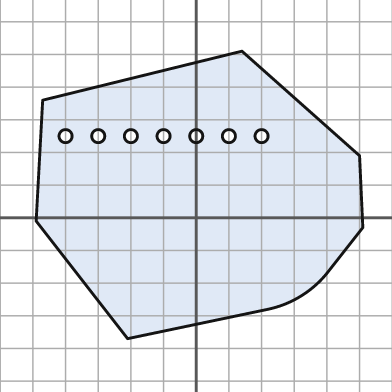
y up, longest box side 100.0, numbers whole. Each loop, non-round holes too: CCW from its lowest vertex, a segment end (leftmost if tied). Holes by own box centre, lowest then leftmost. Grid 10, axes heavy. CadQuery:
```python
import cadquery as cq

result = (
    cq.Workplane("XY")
    .moveTo(-21.0, -37.0)
    .lineTo(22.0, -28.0)
    .threePointArc((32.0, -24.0), (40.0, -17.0))
    .lineTo(51.0, -3.0)
    .lineTo(50.0, 19.0)
    .lineTo(14.0, 51.0)
    .lineTo(-47.0, 36.0)
    .lineTo(-49.0, -1.0)
    .close()
    .moveTo(-40.0, 25.0)
    .circle(2.0)
    .moveTo(-30.0, 25.0)
    .circle(2.0)
    .moveTo(-20.0, 25.0)
    .circle(2.0)
    .moveTo(-10.0, 25.0)
    .circle(2.0)
    .moveTo(0.0, 25.0)
    .circle(2.0)
    .moveTo(10.0, 25.0)
    .circle(2.0)
    .moveTo(20.0, 25.0)
    .circle(2.0)
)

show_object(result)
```